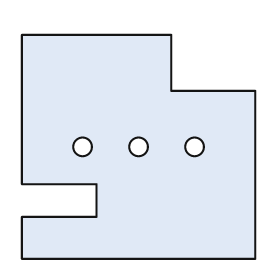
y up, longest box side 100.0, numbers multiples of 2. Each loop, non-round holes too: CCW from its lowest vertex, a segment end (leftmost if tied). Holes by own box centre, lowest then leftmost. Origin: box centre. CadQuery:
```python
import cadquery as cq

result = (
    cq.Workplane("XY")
    .moveTo(-50.0, -48.0)
    .lineTo(50.0, -48.0)
    .lineTo(50.0, 24.0)
    .lineTo(14.0, 24.0)
    .lineTo(14.0, 48.0)
    .lineTo(-50.0, 48.0)
    .lineTo(-50.0, -16.0)
    .lineTo(-18.0, -16.0)
    .lineTo(-18.0, -30.0)
    .lineTo(-50.0, -30.0)
    .close()
    .moveTo(-24.0, 0.0)
    .circle(4.0)
    .moveTo(0.0, 0.0)
    .circle(4.0)
    .moveTo(24.0, 0.0)
    .circle(4.0)
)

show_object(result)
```